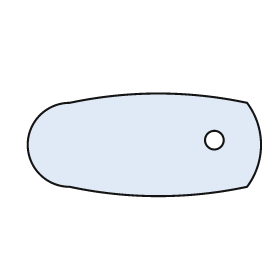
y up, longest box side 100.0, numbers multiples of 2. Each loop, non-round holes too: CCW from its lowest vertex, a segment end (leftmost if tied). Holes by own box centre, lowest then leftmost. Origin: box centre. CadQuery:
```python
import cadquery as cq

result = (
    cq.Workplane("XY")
    .moveTo(-32.0, -18.0)
    .threePointArc((6.0, -22.0), (44.0, -18.0))
    .threePointArc((50.0, 0.0), (44.0, 18.0))
    .threePointArc((6.0, 22.0), (-32.0, 18.0))
    .threePointArc((-50.0, 0.0), (-32.0, -18.0))
    .close()
    .moveTo(30.0, 2.0)
    .circle(4.0)
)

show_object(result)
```